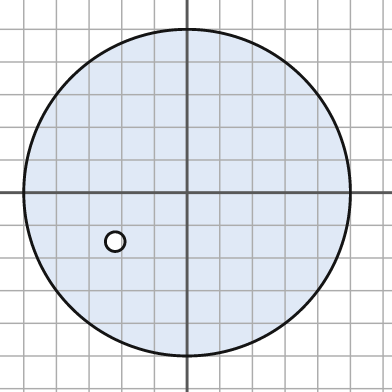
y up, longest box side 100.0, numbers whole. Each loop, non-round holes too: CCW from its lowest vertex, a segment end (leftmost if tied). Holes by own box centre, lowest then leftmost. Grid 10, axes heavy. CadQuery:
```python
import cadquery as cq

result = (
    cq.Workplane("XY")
    .moveTo(0.0, 0.0)
    .circle(50.0)
    .moveTo(-22.0, -15.0)
    .circle(3.0)
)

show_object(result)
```